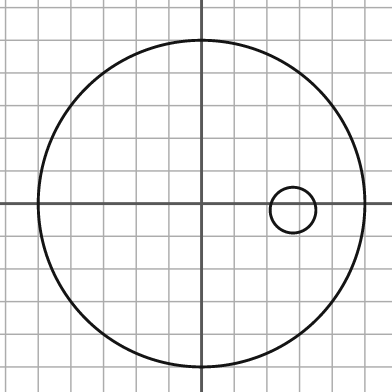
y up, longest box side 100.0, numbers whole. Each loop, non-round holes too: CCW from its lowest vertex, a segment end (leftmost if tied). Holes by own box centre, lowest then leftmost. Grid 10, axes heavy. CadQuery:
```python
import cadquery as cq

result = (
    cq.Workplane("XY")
    .moveTo(0.0, 0.0)
    .circle(50.0)
    .moveTo(28.0, -2.0)
    .circle(7.0)
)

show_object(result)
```